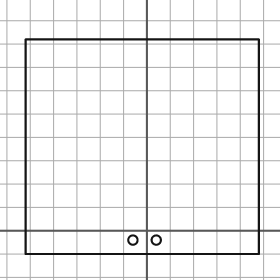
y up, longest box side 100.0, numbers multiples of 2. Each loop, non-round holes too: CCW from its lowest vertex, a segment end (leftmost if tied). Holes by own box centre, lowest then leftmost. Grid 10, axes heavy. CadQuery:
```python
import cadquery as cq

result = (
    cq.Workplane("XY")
    .moveTo(-52.0, -10.0)
    .lineTo(48.0, -10.0)
    .lineTo(48.0, 82.0)
    .lineTo(-52.0, 82.0)
    .close()
    .moveTo(-6.0, -4.0)
    .circle(2.0)
    .moveTo(4.0, -4.0)
    .circle(2.0)
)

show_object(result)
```